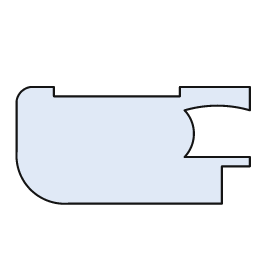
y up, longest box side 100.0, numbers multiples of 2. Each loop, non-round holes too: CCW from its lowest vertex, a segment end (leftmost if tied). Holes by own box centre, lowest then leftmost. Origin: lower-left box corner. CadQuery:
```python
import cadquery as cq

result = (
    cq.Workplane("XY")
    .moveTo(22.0, 0.0)
    .lineTo(88.0, 0.0)
    .lineTo(88.0, 16.0)
    .lineTo(100.0, 16.0)
    .lineTo(100.0, 20.0)
    .lineTo(72.0, 20.0)
    .threePointArc((76.0, 30.0), (72.0, 40.0))
    .threePointArc((86.0, 42.0), (100.0, 40.0))
    .lineTo(100.0, 50.0)
    .lineTo(70.0, 50.0)
    .lineTo(70.0, 46.0)
    .lineTo(16.0, 46.0)
    .lineTo(16.0, 50.0)
    .lineTo(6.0, 50.0)
    .threePointArc((2.0, 48.0), (0.0, 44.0))
    .lineTo(0.0, 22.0)
    .threePointArc((6.0, 6.0), (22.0, 0.0))
    .close()
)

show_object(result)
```